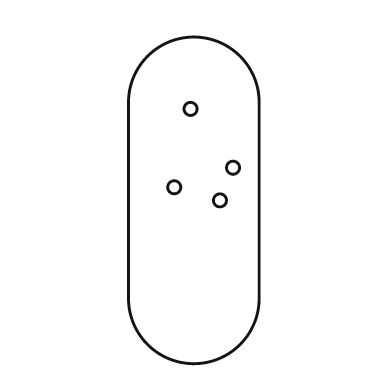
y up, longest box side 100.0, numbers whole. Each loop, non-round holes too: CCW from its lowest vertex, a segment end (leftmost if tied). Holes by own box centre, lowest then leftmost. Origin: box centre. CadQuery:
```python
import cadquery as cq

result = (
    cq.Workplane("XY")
    .moveTo(-20.0, -30.0)
    .threePointArc((0.0, -50.0), (20.0, -30.0))
    .lineTo(20.0, 30.0)
    .threePointArc((0.0, 50.0), (-20.0, 30.0))
    .close()
    .moveTo(8.0, 0.0)
    .circle(2.0)
    .moveTo(-6.0, 4.0)
    .circle(2.0)
    .moveTo(12.0, 10.0)
    .circle(2.0)
    .moveTo(-1.0, 28.0)
    .circle(2.0)
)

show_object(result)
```